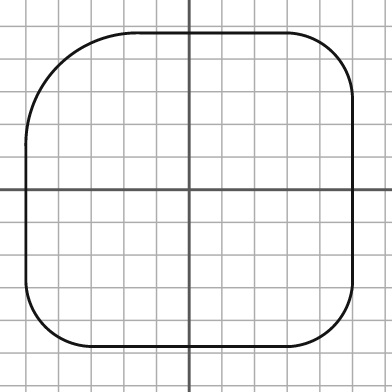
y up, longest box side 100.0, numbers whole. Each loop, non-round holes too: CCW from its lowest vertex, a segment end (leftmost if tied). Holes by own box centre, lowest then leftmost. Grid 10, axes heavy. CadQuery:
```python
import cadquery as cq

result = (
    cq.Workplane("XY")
    .moveTo(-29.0, -48.0)
    .lineTo(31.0, -48.0)
    .threePointArc((44.0, -42.0), (50.0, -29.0))
    .lineTo(50.0, 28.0)
    .threePointArc((44.0, 42.0), (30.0, 48.0))
    .lineTo(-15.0, 48.0)
    .threePointArc((-40.0, 38.0), (-50.0, 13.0))
    .lineTo(-50.0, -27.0)
    .threePointArc((-44.0, -42.0), (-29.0, -48.0))
    .close()
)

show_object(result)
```